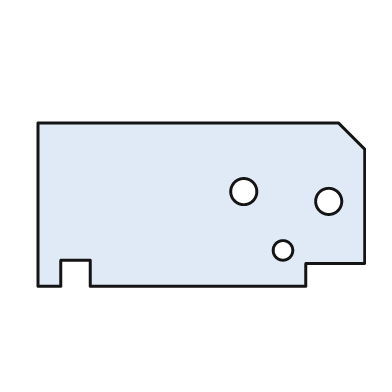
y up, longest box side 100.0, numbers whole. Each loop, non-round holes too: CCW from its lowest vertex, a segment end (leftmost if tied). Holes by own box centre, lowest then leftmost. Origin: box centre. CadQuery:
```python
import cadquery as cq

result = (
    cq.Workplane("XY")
    .moveTo(-50.0, -25.0)
    .lineTo(-43.0, -25.0)
    .lineTo(-43.0, -17.0)
    .lineTo(-34.0, -17.0)
    .lineTo(-34.0, -25.0)
    .lineTo(32.0, -25.0)
    .lineTo(32.0, -18.0)
    .lineTo(50.0, -18.0)
    .lineTo(50.0, 17.0)
    .lineTo(42.0, 25.0)
    .lineTo(-50.0, 25.0)
    .close()
    .moveTo(25.0, -14.0)
    .circle(3.0)
    .moveTo(39.0, 1.0)
    .circle(4.0)
    .moveTo(13.0, 4.0)
    .circle(4.0)
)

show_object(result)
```